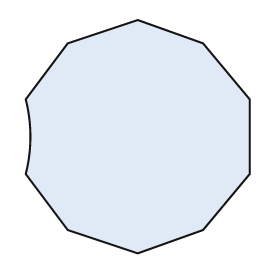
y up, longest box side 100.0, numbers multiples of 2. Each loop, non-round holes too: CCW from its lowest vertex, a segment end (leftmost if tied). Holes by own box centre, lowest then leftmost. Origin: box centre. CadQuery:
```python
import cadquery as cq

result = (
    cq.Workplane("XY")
    .moveTo(0.0, -50.0)
    .lineTo(28.0, -40.0)
    .lineTo(48.0, -16.0)
    .lineTo(48.0, 16.0)
    .lineTo(28.0, 40.0)
    .lineTo(0.0, 50.0)
    .lineTo(-30.0, 40.0)
    .lineTo(-48.0, 16.0)
    .threePointArc((-46.0, 0.0), (-48.0, -16.0))
    .lineTo(-30.0, -40.0)
    .close()
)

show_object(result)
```